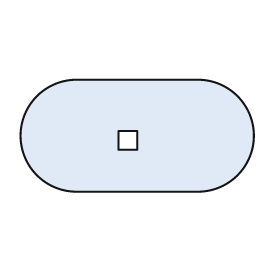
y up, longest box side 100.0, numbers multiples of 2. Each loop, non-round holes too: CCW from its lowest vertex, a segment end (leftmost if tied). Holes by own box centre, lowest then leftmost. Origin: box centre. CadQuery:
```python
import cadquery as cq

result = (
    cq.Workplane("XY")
    .moveTo(-26.0, -24.0)
    .lineTo(26.0, -24.0)
    .threePointArc((50.0, 0.0), (26.0, 24.0))
    .lineTo(-26.0, 24.0)
    .threePointArc((-50.0, 0.0), (-26.0, -24.0))
    .close()
    .moveTo(-8.0, -6.0)
    .lineTo(0.0, -6.0)
    .lineTo(0.0, 2.0)
    .lineTo(-8.0, 2.0)
    .close()
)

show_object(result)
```